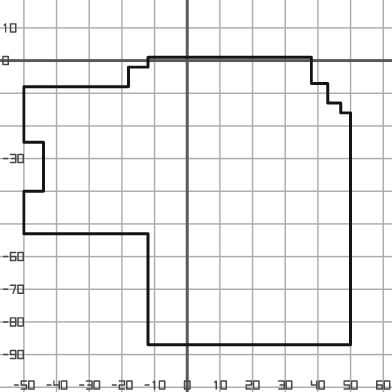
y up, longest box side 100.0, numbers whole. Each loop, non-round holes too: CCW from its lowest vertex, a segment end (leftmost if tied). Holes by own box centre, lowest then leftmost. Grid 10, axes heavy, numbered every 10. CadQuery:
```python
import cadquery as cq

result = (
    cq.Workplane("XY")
    .moveTo(-12.0, -87.0)
    .lineTo(50.0, -87.0)
    .lineTo(50.0, -16.0)
    .lineTo(47.0, -16.0)
    .lineTo(47.0, -13.0)
    .lineTo(43.0, -13.0)
    .lineTo(43.0, -7.0)
    .lineTo(38.0, -7.0)
    .lineTo(38.0, 1.0)
    .lineTo(-12.0, 1.0)
    .lineTo(-12.0, -2.0)
    .lineTo(-18.0, -2.0)
    .lineTo(-18.0, -8.0)
    .lineTo(-50.0, -8.0)
    .lineTo(-50.0, -25.0)
    .lineTo(-44.0, -25.0)
    .lineTo(-44.0, -40.0)
    .lineTo(-50.0, -40.0)
    .lineTo(-50.0, -53.0)
    .lineTo(-12.0, -53.0)
    .close()
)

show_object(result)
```